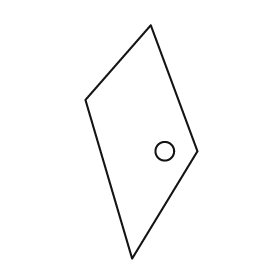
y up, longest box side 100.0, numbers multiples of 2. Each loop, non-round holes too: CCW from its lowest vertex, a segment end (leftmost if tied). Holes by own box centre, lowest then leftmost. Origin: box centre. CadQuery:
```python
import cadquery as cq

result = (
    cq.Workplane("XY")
    .moveTo(-4.0, -50.0)
    .lineTo(24.0, -4.0)
    .lineTo(4.0, 50.0)
    .lineTo(-24.0, 18.0)
    .close()
    .moveTo(10.0, -4.0)
    .circle(4.0)
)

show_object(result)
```